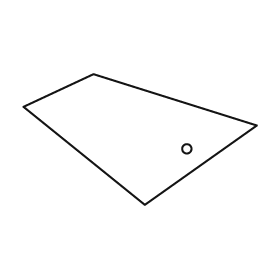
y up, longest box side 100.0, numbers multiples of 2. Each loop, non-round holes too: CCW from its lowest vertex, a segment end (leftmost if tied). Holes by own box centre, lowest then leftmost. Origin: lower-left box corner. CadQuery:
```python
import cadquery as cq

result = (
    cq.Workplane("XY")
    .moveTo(52.0, 0.0)
    .lineTo(100.0, 34.0)
    .lineTo(30.0, 56.0)
    .lineTo(0.0, 42.0)
    .close()
    .moveTo(70.0, 24.0)
    .circle(2.0)
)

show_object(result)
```